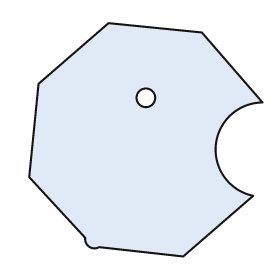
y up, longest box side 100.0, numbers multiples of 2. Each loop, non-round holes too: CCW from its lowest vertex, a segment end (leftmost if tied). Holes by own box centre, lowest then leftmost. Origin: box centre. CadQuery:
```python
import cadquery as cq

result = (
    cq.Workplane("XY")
    .moveTo(16.0, -50.0)
    .lineTo(46.0, -24.0)
    .threePointArc((30.0, -2.0), (50.0, 16.0))
    .lineTo(24.0, 46.0)
    .lineTo(-16.0, 50.0)
    .lineTo(-46.0, 24.0)
    .lineTo(-50.0, -16.0)
    .lineTo(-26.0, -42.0)
    .threePointArc((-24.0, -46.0), (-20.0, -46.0))
    .close()
    .moveTo(0.0, 18.0)
    .circle(4.0)
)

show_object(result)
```